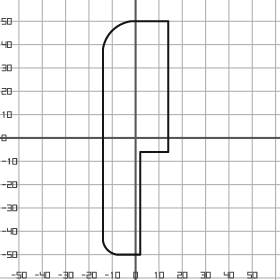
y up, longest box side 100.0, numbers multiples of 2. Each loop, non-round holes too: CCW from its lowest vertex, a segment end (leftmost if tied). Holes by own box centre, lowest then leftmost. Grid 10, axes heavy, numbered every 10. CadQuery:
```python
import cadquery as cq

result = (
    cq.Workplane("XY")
    .moveTo(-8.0, -50.0)
    .lineTo(2.0, -50.0)
    .lineTo(2.0, -6.0)
    .lineTo(14.0, -6.0)
    .lineTo(14.0, 50.0)
    .lineTo(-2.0, 50.0)
    .threePointArc((-10.0, 46.0), (-14.0, 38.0))
    .lineTo(-14.0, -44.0)
    .threePointArc((-12.0, -48.0), (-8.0, -50.0))
    .close()
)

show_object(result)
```